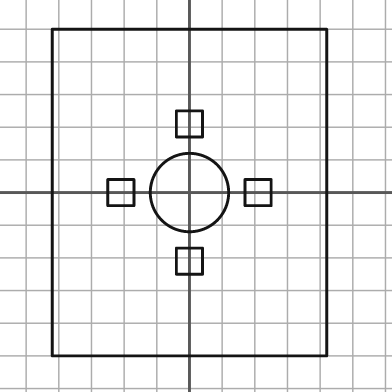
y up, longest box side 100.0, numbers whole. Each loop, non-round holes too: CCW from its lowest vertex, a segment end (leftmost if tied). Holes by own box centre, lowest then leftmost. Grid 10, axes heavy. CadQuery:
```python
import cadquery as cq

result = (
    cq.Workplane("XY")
    .moveTo(-42.0, -50.0)
    .lineTo(42.0, -50.0)
    .lineTo(42.0, 50.0)
    .lineTo(-42.0, 50.0)
    .close()
    .moveTo(-4.0, -25.0)
    .lineTo(4.0, -25.0)
    .lineTo(4.0, -17.0)
    .lineTo(-4.0, -17.0)
    .close()
    .moveTo(-25.0, -4.0)
    .lineTo(-17.0, -4.0)
    .lineTo(-17.0, 4.0)
    .lineTo(-25.0, 4.0)
    .close()
    .moveTo(0.0, 0.0)
    .circle(12.0)
    .moveTo(17.0, -4.0)
    .lineTo(25.0, -4.0)
    .lineTo(25.0, 4.0)
    .lineTo(17.0, 4.0)
    .close()
    .moveTo(-4.0, 17.0)
    .lineTo(4.0, 17.0)
    .lineTo(4.0, 25.0)
    .lineTo(-4.0, 25.0)
    .close()
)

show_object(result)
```